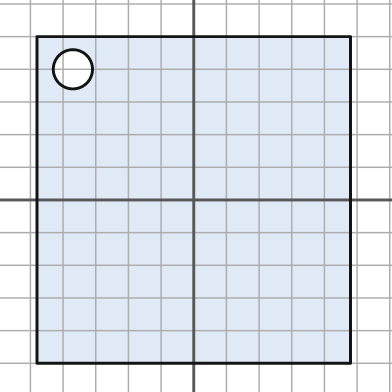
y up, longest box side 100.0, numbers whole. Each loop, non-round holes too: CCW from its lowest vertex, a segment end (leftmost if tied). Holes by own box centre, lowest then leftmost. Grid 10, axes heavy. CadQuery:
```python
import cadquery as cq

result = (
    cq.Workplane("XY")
    .moveTo(-48.0, -50.0)
    .lineTo(48.0, -50.0)
    .lineTo(48.0, 50.0)
    .lineTo(-48.0, 50.0)
    .close()
    .moveTo(-37.0, 40.0)
    .circle(6.0)
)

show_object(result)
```